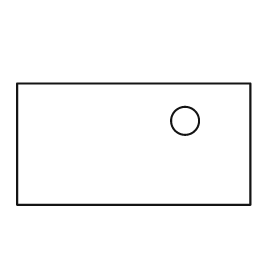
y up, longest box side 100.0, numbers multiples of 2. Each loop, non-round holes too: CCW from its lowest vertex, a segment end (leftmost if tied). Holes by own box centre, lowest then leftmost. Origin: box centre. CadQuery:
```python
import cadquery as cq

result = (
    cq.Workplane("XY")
    .moveTo(-50.0, -26.0)
    .lineTo(50.0, -26.0)
    .lineTo(50.0, 26.0)
    .lineTo(-50.0, 26.0)
    .close()
    .moveTo(22.0, 10.0)
    .circle(6.0)
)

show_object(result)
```